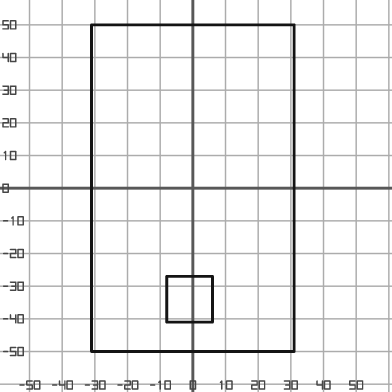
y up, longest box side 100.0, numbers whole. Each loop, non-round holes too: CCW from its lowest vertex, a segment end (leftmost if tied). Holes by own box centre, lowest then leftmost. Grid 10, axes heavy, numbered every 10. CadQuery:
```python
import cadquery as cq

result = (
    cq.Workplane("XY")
    .moveTo(-31.0, -50.0)
    .lineTo(31.0, -50.0)
    .lineTo(31.0, 50.0)
    .lineTo(-31.0, 50.0)
    .close()
    .moveTo(-8.0, -41.0)
    .lineTo(6.0, -41.0)
    .lineTo(6.0, -27.0)
    .lineTo(-8.0, -27.0)
    .close()
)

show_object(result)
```